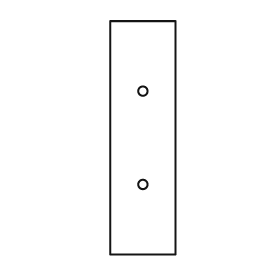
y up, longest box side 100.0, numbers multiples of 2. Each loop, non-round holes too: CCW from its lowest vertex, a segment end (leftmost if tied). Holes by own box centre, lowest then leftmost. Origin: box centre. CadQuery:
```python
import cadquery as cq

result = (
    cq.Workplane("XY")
    .moveTo(-14.0, -50.0)
    .lineTo(14.0, -50.0)
    .lineTo(14.0, 50.0)
    .lineTo(-14.0, 50.0)
    .close()
    .moveTo(0.0, -20.0)
    .circle(2.0)
    .moveTo(0.0, 20.0)
    .circle(2.0)
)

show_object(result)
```